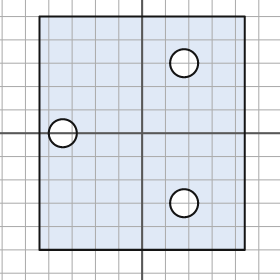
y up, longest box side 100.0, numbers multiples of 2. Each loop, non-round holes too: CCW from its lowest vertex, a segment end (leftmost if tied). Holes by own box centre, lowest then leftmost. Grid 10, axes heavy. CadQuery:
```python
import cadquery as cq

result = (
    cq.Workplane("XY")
    .moveTo(-44.0, -50.0)
    .lineTo(44.0, -50.0)
    .lineTo(44.0, 50.0)
    .lineTo(-44.0, 50.0)
    .close()
    .moveTo(18.0, -30.0)
    .circle(6.0)
    .moveTo(-34.0, 0.0)
    .circle(6.0)
    .moveTo(18.0, 30.0)
    .circle(6.0)
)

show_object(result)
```